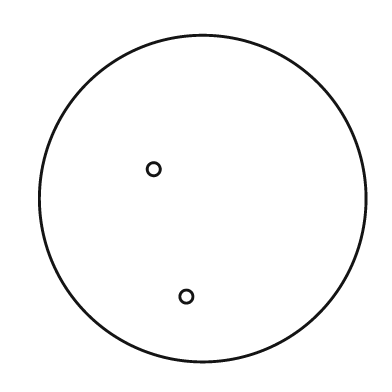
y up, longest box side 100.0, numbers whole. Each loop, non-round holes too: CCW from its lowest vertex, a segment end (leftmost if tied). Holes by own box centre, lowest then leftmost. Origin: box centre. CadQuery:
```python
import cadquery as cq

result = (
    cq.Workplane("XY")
    .moveTo(0.0, 0.0)
    .circle(50.0)
    .moveTo(-5.0, -30.0)
    .circle(2.0)
    .moveTo(-15.0, 9.0)
    .circle(2.0)
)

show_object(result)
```